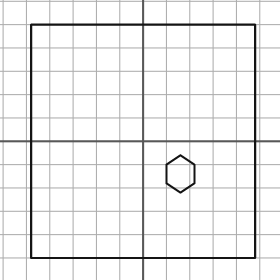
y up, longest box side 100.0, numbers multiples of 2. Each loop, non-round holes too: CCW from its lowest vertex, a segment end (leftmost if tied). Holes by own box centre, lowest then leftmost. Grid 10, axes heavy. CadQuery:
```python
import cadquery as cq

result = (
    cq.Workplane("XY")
    .moveTo(-48.0, -50.0)
    .lineTo(48.0, -50.0)
    .lineTo(48.0, 50.0)
    .lineTo(-48.0, 50.0)
    .close()
    .moveTo(16.0, -22.0)
    .lineTo(22.0, -18.0)
    .lineTo(22.0, -10.0)
    .lineTo(16.0, -6.0)
    .lineTo(10.0, -10.0)
    .lineTo(10.0, -18.0)
    .close()
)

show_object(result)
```